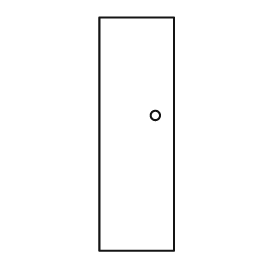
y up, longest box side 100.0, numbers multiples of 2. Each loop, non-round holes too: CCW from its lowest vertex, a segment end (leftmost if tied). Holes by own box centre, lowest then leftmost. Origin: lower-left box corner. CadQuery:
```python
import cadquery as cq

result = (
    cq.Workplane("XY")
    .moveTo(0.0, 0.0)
    .lineTo(32.0, 0.0)
    .lineTo(32.0, 100.0)
    .lineTo(0.0, 100.0)
    .close()
    .moveTo(24.0, 58.0)
    .circle(2.0)
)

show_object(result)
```